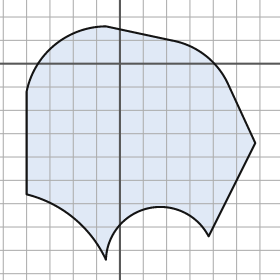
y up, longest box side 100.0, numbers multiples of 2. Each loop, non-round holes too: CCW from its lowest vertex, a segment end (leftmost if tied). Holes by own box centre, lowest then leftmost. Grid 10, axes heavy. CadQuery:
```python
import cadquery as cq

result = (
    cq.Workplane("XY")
    .moveTo(-6.0, -84.0)
    .threePointArc((12.0, -62.0), (38.0, -74.0))
    .lineTo(58.0, -34.0)
    .lineTo(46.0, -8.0)
    .threePointArc((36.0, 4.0), (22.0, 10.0))
    .lineTo(-6.0, 16.0)
    .threePointArc((-28.0, 8.0), (-40.0, -12.0))
    .lineTo(-40.0, -56.0)
    .threePointArc((-20.0, -66.0), (-6.0, -84.0))
    .close()
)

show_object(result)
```